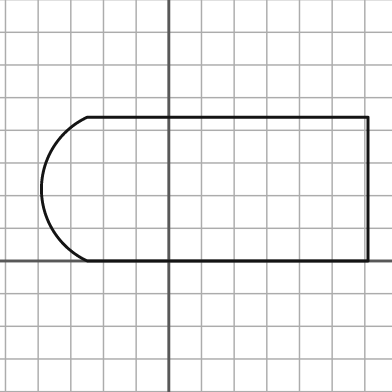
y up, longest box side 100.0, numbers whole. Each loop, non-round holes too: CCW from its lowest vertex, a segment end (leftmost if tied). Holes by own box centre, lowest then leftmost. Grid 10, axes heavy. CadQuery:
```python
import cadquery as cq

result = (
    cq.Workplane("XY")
    .moveTo(-25.0, 0.0)
    .lineTo(61.0, 0.0)
    .lineTo(61.0, 44.0)
    .lineTo(-25.0, 44.0)
    .threePointArc((-39.0, 22.0), (-25.0, 0.0))
    .close()
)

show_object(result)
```